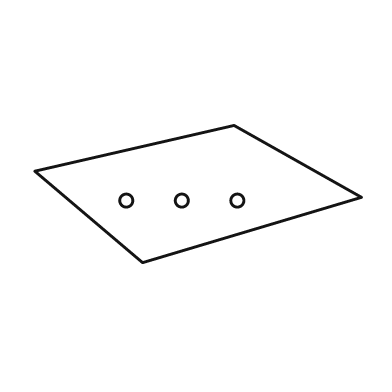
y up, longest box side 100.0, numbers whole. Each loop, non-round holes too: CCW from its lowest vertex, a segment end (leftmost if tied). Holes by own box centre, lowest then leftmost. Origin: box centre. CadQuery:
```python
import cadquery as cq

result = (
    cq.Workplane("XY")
    .moveTo(-17.0, -21.0)
    .lineTo(50.0, -1.0)
    .lineTo(11.0, 21.0)
    .lineTo(-50.0, 7.0)
    .close()
    .moveTo(-22.0, -2.0)
    .circle(2.0)
    .moveTo(-5.0, -2.0)
    .circle(2.0)
    .moveTo(12.0, -2.0)
    .circle(2.0)
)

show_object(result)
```